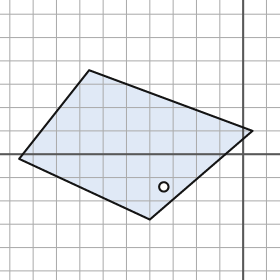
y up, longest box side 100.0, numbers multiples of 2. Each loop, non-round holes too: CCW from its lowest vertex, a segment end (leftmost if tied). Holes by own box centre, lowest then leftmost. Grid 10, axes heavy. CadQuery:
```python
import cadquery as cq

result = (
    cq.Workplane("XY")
    .moveTo(-40.0, -28.0)
    .lineTo(4.0, 10.0)
    .lineTo(-66.0, 36.0)
    .lineTo(-96.0, -2.0)
    .close()
    .moveTo(-34.0, -14.0)
    .circle(2.0)
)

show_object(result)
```